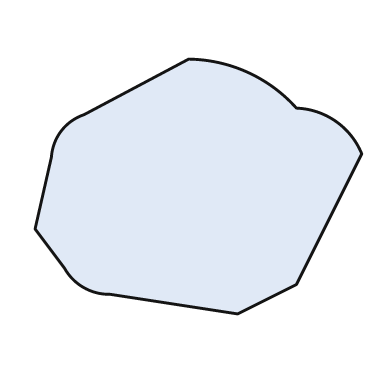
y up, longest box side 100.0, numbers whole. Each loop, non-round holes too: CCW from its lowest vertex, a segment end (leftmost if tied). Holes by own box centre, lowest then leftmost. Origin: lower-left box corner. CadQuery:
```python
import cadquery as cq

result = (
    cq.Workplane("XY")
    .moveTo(62.0, 0.0)
    .lineTo(80.0, 9.0)
    .lineTo(100.0, 49.0)
    .threePointArc((92.0, 59.0), (80.0, 63.0))
    .threePointArc((65.0, 74.0), (47.0, 78.0))
    .lineTo(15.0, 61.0)
    .threePointArc((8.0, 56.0), (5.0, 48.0))
    .lineTo(0.0, 26.0)
    .lineTo(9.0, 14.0)
    .threePointArc((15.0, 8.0), (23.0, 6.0))
    .close()
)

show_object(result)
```